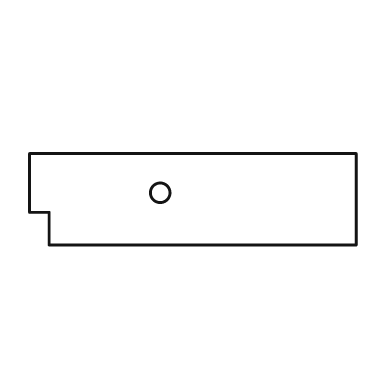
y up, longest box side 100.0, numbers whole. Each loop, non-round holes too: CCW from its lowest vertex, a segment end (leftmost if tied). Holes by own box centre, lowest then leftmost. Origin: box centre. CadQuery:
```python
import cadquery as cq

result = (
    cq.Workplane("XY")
    .moveTo(-44.0, -14.0)
    .lineTo(50.0, -14.0)
    .lineTo(50.0, 14.0)
    .lineTo(-50.0, 14.0)
    .lineTo(-50.0, -4.0)
    .lineTo(-44.0, -4.0)
    .close()
    .moveTo(-10.0, 2.0)
    .circle(3.0)
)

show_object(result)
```